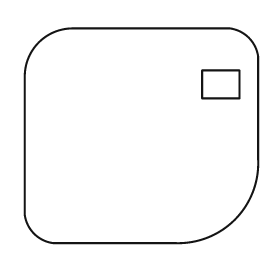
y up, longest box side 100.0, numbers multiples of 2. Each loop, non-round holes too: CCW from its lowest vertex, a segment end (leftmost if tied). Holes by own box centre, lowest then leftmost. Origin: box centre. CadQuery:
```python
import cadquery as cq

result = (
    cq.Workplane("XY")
    .moveTo(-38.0, -46.0)
    .lineTo(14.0, -46.0)
    .threePointArc((40.0, -36.0), (50.0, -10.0))
    .lineTo(50.0, 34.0)
    .threePointArc((46.0, 42.0), (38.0, 46.0))
    .lineTo(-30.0, 46.0)
    .threePointArc((-44.0, 40.0), (-50.0, 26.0))
    .lineTo(-50.0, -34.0)
    .threePointArc((-46.0, -42.0), (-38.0, -46.0))
    .close()
    .moveTo(26.0, 16.0)
    .lineTo(42.0, 16.0)
    .lineTo(42.0, 28.0)
    .lineTo(26.0, 28.0)
    .close()
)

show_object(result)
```